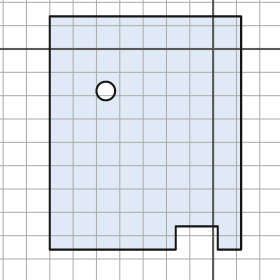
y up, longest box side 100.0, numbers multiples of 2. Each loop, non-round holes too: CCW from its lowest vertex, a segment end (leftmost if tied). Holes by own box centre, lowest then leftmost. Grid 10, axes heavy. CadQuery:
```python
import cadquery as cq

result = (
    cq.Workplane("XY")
    .moveTo(-70.0, -86.0)
    .lineTo(-16.0, -86.0)
    .lineTo(-16.0, -76.0)
    .lineTo(2.0, -76.0)
    .lineTo(2.0, -86.0)
    .lineTo(12.0, -86.0)
    .lineTo(12.0, 14.0)
    .lineTo(-70.0, 14.0)
    .close()
    .moveTo(-46.0, -18.0)
    .circle(4.0)
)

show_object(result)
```